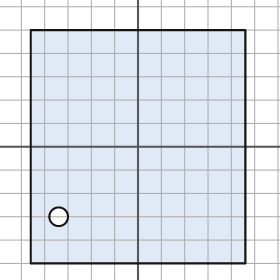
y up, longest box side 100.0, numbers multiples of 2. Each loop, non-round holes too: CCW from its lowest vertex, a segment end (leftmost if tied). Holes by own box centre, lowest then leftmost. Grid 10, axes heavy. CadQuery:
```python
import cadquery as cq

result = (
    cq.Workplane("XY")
    .moveTo(-46.0, -50.0)
    .lineTo(46.0, -50.0)
    .lineTo(46.0, 50.0)
    .lineTo(-46.0, 50.0)
    .close()
    .moveTo(-34.0, -30.0)
    .circle(4.0)
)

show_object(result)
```